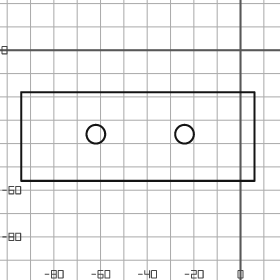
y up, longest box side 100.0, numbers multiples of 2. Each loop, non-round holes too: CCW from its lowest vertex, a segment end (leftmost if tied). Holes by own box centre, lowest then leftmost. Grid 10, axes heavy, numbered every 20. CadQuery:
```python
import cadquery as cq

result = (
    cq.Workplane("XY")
    .moveTo(-94.0, -56.0)
    .lineTo(6.0, -56.0)
    .lineTo(6.0, -18.0)
    .lineTo(-94.0, -18.0)
    .close()
    .moveTo(-62.0, -36.0)
    .circle(4.0)
    .moveTo(-24.0, -36.0)
    .circle(4.0)
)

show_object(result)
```